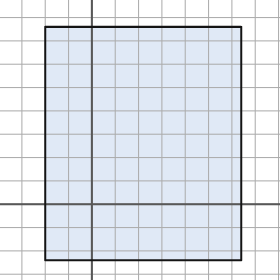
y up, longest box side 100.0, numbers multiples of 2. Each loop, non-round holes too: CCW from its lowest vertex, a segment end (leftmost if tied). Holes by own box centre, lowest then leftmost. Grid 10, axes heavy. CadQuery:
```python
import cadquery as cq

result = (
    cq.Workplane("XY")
    .moveTo(-20.0, -24.0)
    .lineTo(64.0, -24.0)
    .lineTo(64.0, 76.0)
    .lineTo(-20.0, 76.0)
    .close()
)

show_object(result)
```